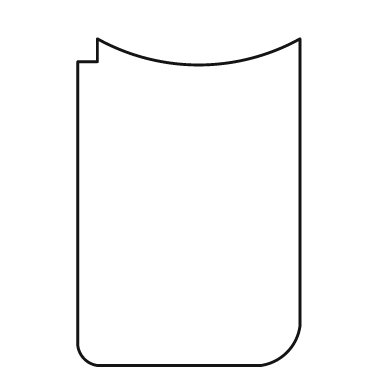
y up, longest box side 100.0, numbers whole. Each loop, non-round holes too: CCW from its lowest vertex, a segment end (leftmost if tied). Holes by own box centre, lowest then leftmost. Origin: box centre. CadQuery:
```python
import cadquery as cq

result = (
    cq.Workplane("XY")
    .moveTo(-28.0, -50.0)
    .lineTo(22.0, -50.0)
    .threePointArc((30.0, -46.0), (34.0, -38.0))
    .lineTo(34.0, 50.0)
    .threePointArc((3.0, 42.0), (-28.0, 50.0))
    .lineTo(-28.0, 43.0)
    .lineTo(-34.0, 43.0)
    .lineTo(-34.0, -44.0)
    .threePointArc((-32.0, -48.0), (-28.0, -50.0))
    .close()
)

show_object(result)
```